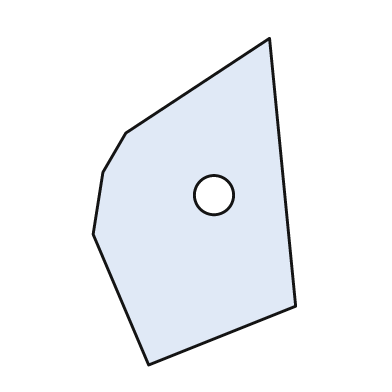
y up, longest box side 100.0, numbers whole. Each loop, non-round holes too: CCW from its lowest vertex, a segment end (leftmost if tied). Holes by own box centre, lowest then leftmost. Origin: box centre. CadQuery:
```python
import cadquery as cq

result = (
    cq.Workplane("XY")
    .moveTo(-14.0, -50.0)
    .lineTo(31.0, -32.0)
    .lineTo(23.0, 50.0)
    .lineTo(-21.0, 21.0)
    .lineTo(-28.0, 9.0)
    .lineTo(-31.0, -10.0)
    .close()
    .moveTo(6.0, 2.0)
    .circle(6.0)
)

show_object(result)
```